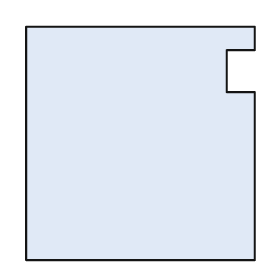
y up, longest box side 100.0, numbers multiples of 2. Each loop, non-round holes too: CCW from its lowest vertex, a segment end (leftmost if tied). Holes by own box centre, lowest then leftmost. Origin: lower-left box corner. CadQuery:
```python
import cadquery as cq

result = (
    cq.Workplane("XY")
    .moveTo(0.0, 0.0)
    .lineTo(98.0, 0.0)
    .lineTo(98.0, 72.0)
    .lineTo(86.0, 72.0)
    .lineTo(86.0, 90.0)
    .lineTo(98.0, 90.0)
    .lineTo(98.0, 100.0)
    .lineTo(0.0, 100.0)
    .close()
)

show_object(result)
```